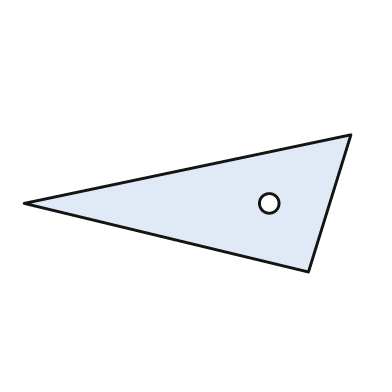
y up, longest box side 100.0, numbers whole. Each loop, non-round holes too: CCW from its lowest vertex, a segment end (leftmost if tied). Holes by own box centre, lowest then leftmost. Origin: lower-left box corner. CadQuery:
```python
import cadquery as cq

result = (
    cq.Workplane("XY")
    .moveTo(87.0, 0.0)
    .lineTo(100.0, 42.0)
    .lineTo(0.0, 21.0)
    .close()
    .moveTo(75.0, 21.0)
    .circle(3.0)
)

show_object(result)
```